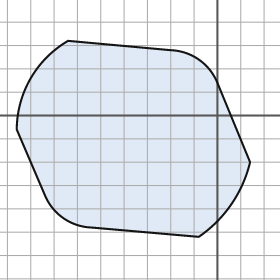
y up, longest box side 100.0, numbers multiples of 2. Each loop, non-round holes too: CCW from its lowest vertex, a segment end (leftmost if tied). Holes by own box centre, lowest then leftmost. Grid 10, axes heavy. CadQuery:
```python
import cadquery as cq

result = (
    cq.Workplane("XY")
    .moveTo(-8.0, -52.0)
    .threePointArc((6.0, -38.0), (14.0, -20.0))
    .lineTo(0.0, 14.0)
    .threePointArc((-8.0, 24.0), (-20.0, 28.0))
    .lineTo(-64.0, 32.0)
    .threePointArc((-80.0, 16.0), (-86.0, -6.0))
    .lineTo(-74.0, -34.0)
    .threePointArc((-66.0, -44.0), (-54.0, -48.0))
    .close()
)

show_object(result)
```